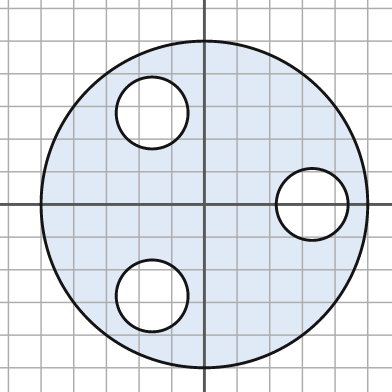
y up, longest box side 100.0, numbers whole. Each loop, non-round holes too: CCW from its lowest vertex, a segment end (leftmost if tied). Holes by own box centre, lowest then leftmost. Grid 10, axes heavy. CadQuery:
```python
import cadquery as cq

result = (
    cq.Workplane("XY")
    .moveTo(0.0, 0.0)
    .circle(50.0)
    .moveTo(-16.0, -28.0)
    .circle(11.0)
    .moveTo(33.0, 0.0)
    .circle(11.0)
    .moveTo(-16.0, 28.0)
    .circle(11.0)
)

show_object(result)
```